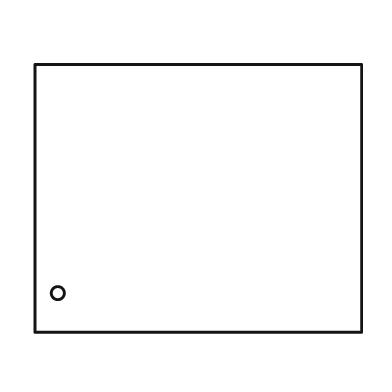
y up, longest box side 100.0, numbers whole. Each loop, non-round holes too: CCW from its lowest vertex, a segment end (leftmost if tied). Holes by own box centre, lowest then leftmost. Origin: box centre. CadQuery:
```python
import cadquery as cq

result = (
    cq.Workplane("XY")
    .moveTo(-50.0, -41.0)
    .lineTo(50.0, -41.0)
    .lineTo(50.0, 41.0)
    .lineTo(-50.0, 41.0)
    .close()
    .moveTo(-43.0, -29.0)
    .circle(2.0)
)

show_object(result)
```